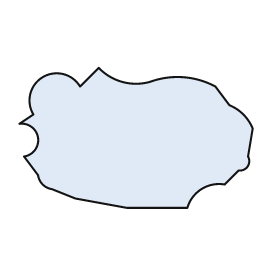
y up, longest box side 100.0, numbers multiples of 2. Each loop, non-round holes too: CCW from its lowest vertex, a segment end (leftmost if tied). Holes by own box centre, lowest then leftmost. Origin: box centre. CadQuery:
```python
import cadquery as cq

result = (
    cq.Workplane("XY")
    .moveTo(-4.0, -30.0)
    .lineTo(22.0, -30.0)
    .threePointArc((28.0, -22.0), (38.0, -20.0))
    .lineTo(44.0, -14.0)
    .threePointArc((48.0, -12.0), (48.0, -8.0))
    .lineTo(50.0, 4.0)
    .threePointArc((46.0, 10.0), (40.0, 14.0))
    .lineTo(34.0, 22.0)
    .threePointArc((20.0, 26.0), (6.0, 24.0))
    .threePointArc((-6.0, 24.0), (-16.0, 30.0))
    .lineTo(-24.0, 22.0)
    .threePointArc((-40.0, 26.0), (-44.0, 10.0))
    .lineTo(-50.0, 6.0)
    .threePointArc((-42.0, 0.0), (-48.0, -8.0))
    .lineTo(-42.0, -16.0)
    .threePointArc((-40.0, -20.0), (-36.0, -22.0))
    .lineTo(-26.0, -26.0)
    .close()
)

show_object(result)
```